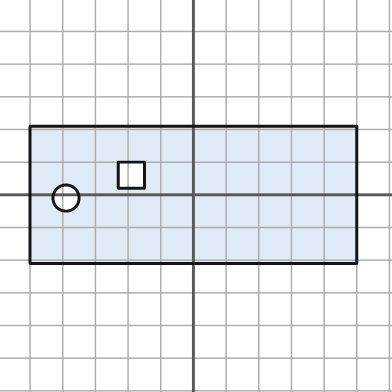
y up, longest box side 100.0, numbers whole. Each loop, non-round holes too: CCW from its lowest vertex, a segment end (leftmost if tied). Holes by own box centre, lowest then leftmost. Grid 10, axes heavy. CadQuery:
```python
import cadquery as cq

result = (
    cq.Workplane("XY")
    .moveTo(-50.0, -21.0)
    .lineTo(50.0, -21.0)
    .lineTo(50.0, 21.0)
    .lineTo(-50.0, 21.0)
    .close()
    .moveTo(-39.0, -1.0)
    .circle(4.0)
    .moveTo(-23.0, 2.0)
    .lineTo(-15.0, 2.0)
    .lineTo(-15.0, 10.0)
    .lineTo(-23.0, 10.0)
    .close()
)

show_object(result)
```